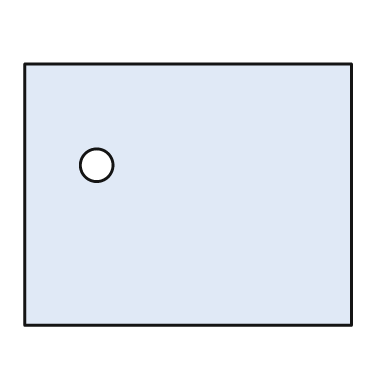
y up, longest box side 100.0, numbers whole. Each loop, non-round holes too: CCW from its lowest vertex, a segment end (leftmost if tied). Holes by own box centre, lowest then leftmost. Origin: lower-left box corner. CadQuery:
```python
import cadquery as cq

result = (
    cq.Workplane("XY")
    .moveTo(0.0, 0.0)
    .lineTo(100.0, 0.0)
    .lineTo(100.0, 80.0)
    .lineTo(0.0, 80.0)
    .close()
    .moveTo(22.0, 49.0)
    .circle(5.0)
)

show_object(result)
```